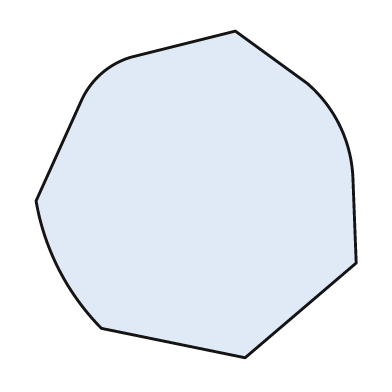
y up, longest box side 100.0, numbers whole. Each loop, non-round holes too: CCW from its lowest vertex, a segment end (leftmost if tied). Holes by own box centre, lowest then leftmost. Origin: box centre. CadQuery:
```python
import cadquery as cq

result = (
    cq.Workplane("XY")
    .moveTo(15.0, -50.0)
    .lineTo(49.0, -21.0)
    .lineTo(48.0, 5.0)
    .threePointArc((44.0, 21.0), (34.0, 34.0))
    .lineTo(12.0, 50.0)
    .lineTo(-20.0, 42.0)
    .threePointArc((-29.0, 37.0), (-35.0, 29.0))
    .lineTo(-49.0, -2.0)
    .threePointArc((-42.0, -23.0), (-29.0, -41.0))
    .close()
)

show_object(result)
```